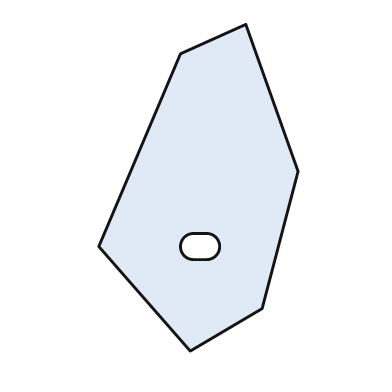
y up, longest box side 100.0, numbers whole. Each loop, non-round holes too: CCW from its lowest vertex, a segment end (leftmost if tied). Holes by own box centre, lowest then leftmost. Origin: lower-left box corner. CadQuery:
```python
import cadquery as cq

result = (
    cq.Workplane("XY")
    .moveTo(28.0, 0.0)
    .lineTo(50.0, 13.0)
    .lineTo(61.0, 55.0)
    .lineTo(45.0, 100.0)
    .lineTo(25.0, 91.0)
    .lineTo(0.0, 32.0)
    .close()
    .moveTo(29.0, 28.0)
    .lineTo(33.0, 28.0)
    .threePointArc((37.0, 32.0), (33.0, 36.0))
    .lineTo(29.0, 36.0)
    .threePointArc((25.0, 32.0), (29.0, 28.0))
    .close()
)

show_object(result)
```